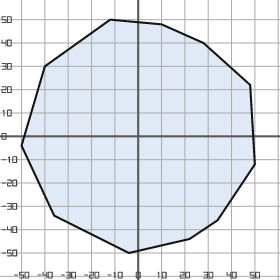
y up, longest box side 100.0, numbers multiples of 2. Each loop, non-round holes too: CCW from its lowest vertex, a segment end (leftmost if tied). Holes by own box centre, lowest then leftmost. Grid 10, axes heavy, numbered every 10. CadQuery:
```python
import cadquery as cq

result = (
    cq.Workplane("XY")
    .moveTo(-4.0, -50.0)
    .lineTo(22.0, -44.0)
    .lineTo(34.0, -36.0)
    .lineTo(50.0, -12.0)
    .lineTo(48.0, 22.0)
    .lineTo(28.0, 40.0)
    .lineTo(10.0, 48.0)
    .lineTo(-12.0, 50.0)
    .lineTo(-40.0, 30.0)
    .lineTo(-50.0, -4.0)
    .lineTo(-36.0, -34.0)
    .close()
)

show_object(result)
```